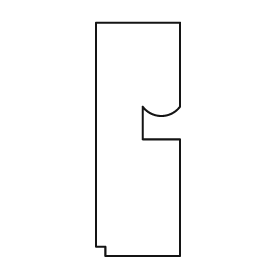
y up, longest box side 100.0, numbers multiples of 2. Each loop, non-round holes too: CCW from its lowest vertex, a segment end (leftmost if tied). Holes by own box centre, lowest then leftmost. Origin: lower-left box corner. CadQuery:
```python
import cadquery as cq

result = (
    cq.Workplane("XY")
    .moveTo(4.0, 0.0)
    .lineTo(36.0, 0.0)
    .lineTo(36.0, 50.0)
    .lineTo(20.0, 50.0)
    .lineTo(20.0, 64.0)
    .threePointArc((28.0, 60.0), (36.0, 64.0))
    .lineTo(36.0, 100.0)
    .lineTo(0.0, 100.0)
    .lineTo(0.0, 4.0)
    .lineTo(4.0, 4.0)
    .close()
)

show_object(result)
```